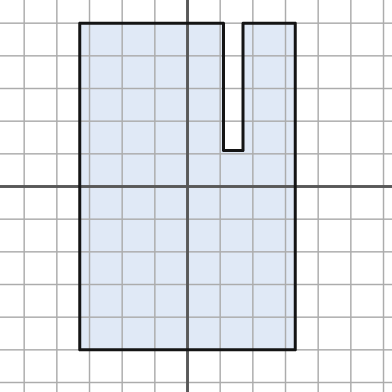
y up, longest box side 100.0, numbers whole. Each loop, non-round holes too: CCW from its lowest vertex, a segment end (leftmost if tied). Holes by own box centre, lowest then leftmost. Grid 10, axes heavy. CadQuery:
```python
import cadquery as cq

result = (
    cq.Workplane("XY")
    .moveTo(-33.0, -50.0)
    .lineTo(33.0, -50.0)
    .lineTo(33.0, 50.0)
    .lineTo(17.0, 50.0)
    .lineTo(17.0, 11.0)
    .lineTo(11.0, 11.0)
    .lineTo(11.0, 50.0)
    .lineTo(-33.0, 50.0)
    .close()
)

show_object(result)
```